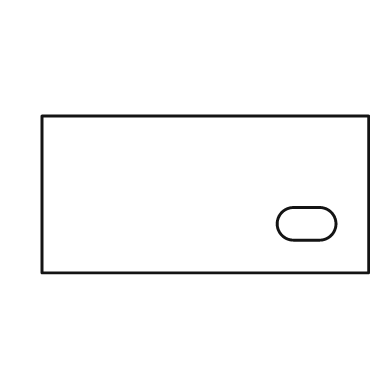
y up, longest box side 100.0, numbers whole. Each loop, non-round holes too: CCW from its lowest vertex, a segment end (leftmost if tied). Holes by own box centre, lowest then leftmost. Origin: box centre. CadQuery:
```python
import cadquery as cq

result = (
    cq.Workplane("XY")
    .moveTo(-50.0, -24.0)
    .lineTo(50.0, -24.0)
    .lineTo(50.0, 24.0)
    .lineTo(-50.0, 24.0)
    .close()
    .moveTo(27.0, -14.0)
    .lineTo(35.0, -14.0)
    .threePointArc((40.0, -9.0), (35.0, -4.0))
    .lineTo(27.0, -4.0)
    .threePointArc((22.0, -9.0), (27.0, -14.0))
    .close()
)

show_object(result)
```